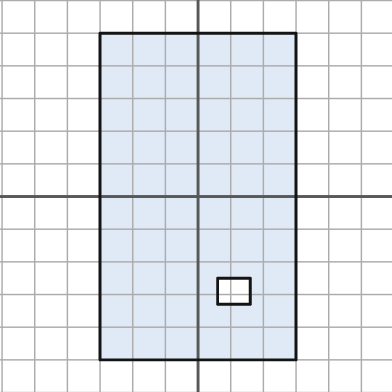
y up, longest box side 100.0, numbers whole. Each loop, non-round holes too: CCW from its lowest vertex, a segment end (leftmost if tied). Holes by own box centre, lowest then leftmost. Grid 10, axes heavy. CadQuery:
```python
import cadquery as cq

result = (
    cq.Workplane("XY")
    .moveTo(-30.0, -50.0)
    .lineTo(30.0, -50.0)
    .lineTo(30.0, 50.0)
    .lineTo(-30.0, 50.0)
    .close()
    .moveTo(6.0, -33.0)
    .lineTo(16.0, -33.0)
    .lineTo(16.0, -25.0)
    .lineTo(6.0, -25.0)
    .close()
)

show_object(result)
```